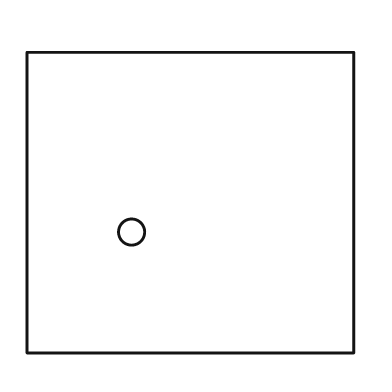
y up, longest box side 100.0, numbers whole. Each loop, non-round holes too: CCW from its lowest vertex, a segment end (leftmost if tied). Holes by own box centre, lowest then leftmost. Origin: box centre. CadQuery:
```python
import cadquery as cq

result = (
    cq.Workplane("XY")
    .moveTo(-50.0, -46.0)
    .lineTo(50.0, -46.0)
    .lineTo(50.0, 46.0)
    .lineTo(-50.0, 46.0)
    .close()
    .moveTo(-18.0, -9.0)
    .circle(4.0)
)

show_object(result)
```